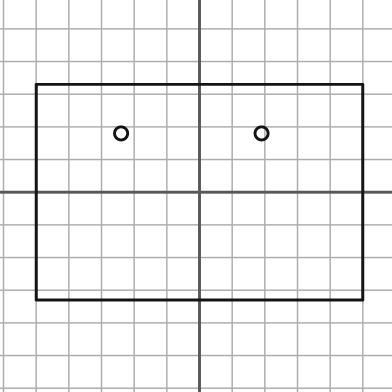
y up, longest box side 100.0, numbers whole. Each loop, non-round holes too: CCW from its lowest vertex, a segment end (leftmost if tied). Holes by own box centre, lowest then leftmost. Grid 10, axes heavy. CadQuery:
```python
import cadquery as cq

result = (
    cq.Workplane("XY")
    .moveTo(-50.0, -33.0)
    .lineTo(50.0, -33.0)
    .lineTo(50.0, 33.0)
    .lineTo(-50.0, 33.0)
    .close()
    .moveTo(-24.0, 18.0)
    .circle(2.0)
    .moveTo(19.0, 18.0)
    .circle(2.0)
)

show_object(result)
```